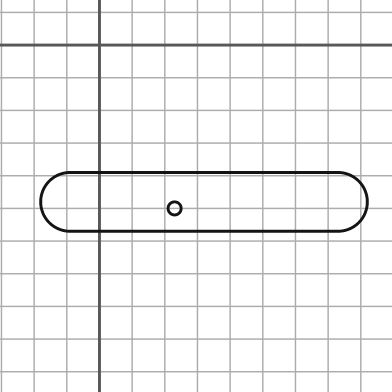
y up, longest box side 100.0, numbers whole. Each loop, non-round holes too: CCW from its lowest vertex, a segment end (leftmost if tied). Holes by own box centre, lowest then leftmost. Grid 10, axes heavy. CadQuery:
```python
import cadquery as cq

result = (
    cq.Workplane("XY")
    .moveTo(-9.0, -57.0)
    .lineTo(73.0, -57.0)
    .threePointArc((82.0, -48.0), (73.0, -39.0))
    .lineTo(-9.0, -39.0)
    .threePointArc((-18.0, -48.0), (-9.0, -57.0))
    .close()
    .moveTo(23.0, -50.0)
    .circle(2.0)
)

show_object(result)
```